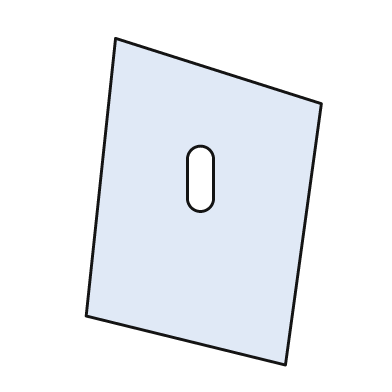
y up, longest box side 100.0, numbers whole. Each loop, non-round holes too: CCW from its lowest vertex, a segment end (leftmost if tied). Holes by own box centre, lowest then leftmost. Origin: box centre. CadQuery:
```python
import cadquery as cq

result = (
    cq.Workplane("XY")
    .moveTo(25.0, -50.0)
    .lineTo(36.0, 30.0)
    .lineTo(-27.0, 50.0)
    .lineTo(-36.0, -35.0)
    .close()
    .moveTo(-5.0, 1.0)
    .threePointArc((-1.0, -3.0), (3.0, 1.0))
    .lineTo(3.0, 13.0)
    .threePointArc((-1.0, 17.0), (-5.0, 13.0))
    .close()
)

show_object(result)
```